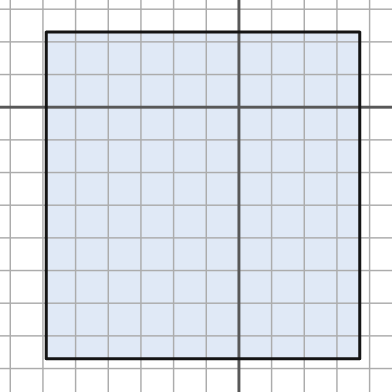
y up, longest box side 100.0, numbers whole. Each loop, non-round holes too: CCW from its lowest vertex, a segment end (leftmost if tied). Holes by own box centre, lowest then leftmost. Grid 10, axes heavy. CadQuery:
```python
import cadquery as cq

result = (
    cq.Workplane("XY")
    .moveTo(-59.0, -77.0)
    .lineTo(37.0, -77.0)
    .lineTo(37.0, 23.0)
    .lineTo(-59.0, 23.0)
    .close()
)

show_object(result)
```